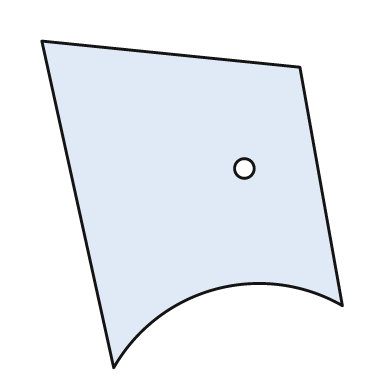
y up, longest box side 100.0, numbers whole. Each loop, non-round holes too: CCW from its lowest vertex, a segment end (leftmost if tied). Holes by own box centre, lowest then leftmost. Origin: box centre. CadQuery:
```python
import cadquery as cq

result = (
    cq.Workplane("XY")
    .moveTo(-24.0, -50.0)
    .threePointArc((7.0, -26.0), (46.0, -31.0))
    .lineTo(33.0, 42.0)
    .lineTo(-46.0, 50.0)
    .close()
    .moveTo(16.0, 11.0)
    .circle(3.0)
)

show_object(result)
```